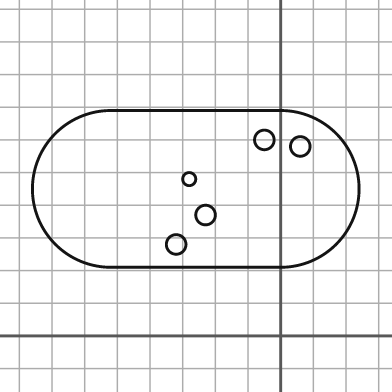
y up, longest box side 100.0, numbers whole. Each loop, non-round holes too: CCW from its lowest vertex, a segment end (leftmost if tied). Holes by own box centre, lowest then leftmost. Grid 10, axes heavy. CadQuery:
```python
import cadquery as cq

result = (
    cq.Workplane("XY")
    .moveTo(-52.0, 21.0)
    .lineTo(0.0, 21.0)
    .threePointArc((24.0, 45.0), (0.0, 69.0))
    .lineTo(-52.0, 69.0)
    .threePointArc((-76.0, 45.0), (-52.0, 21.0))
    .close()
    .moveTo(-32.0, 28.0)
    .circle(3.0)
    .moveTo(-23.0, 37.0)
    .circle(3.0)
    .moveTo(-28.0, 48.0)
    .circle(2.0)
    .moveTo(6.0, 58.0)
    .circle(3.0)
    .moveTo(-5.0, 60.0)
    .circle(3.0)
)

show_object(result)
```